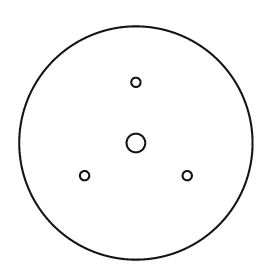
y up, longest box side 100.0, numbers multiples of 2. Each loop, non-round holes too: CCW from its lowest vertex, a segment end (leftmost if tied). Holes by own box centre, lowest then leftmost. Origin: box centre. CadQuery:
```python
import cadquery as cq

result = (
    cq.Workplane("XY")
    .moveTo(0.0, 0.0)
    .circle(50.0)
    .moveTo(-22.0, -14.0)
    .circle(2.0)
    .moveTo(22.0, -14.0)
    .circle(2.0)
    .moveTo(0.0, 0.0)
    .circle(4.0)
    .moveTo(0.0, 26.0)
    .circle(2.0)
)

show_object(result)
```